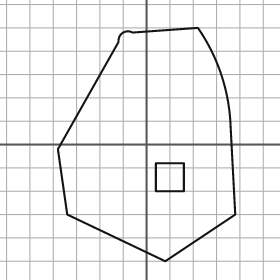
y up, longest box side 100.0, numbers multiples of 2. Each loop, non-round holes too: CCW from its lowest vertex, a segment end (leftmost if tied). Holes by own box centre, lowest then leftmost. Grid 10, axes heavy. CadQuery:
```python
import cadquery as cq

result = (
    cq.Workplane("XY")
    .moveTo(8.0, -50.0)
    .lineTo(38.0, -30.0)
    .lineTo(36.0, 8.0)
    .threePointArc((32.0, 30.0), (22.0, 50.0))
    .lineTo(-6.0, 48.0)
    .threePointArc((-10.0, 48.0), (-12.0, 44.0))
    .lineTo(-38.0, -2.0)
    .lineTo(-34.0, -30.0)
    .close()
    .moveTo(4.0, -20.0)
    .lineTo(16.0, -20.0)
    .lineTo(16.0, -8.0)
    .lineTo(4.0, -8.0)
    .close()
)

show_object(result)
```